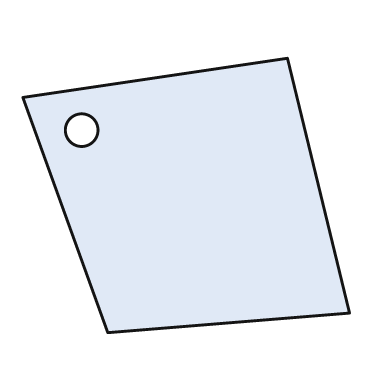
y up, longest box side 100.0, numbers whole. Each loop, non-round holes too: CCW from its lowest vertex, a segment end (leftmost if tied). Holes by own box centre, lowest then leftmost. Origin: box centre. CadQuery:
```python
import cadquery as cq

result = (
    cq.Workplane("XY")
    .moveTo(-24.0, -42.0)
    .lineTo(50.0, -36.0)
    .lineTo(31.0, 42.0)
    .lineTo(-50.0, 30.0)
    .close()
    .moveTo(-32.0, 20.0)
    .circle(5.0)
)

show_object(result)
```